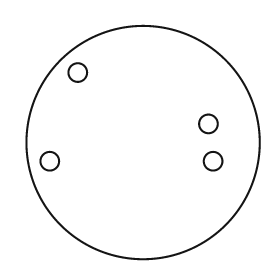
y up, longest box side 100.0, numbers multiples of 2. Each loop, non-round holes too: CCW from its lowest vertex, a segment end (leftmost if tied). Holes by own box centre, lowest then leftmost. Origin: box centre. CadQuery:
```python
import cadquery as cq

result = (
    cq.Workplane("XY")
    .moveTo(0.0, 0.0)
    .circle(50.0)
    .moveTo(-40.0, -8.0)
    .circle(4.0)
    .moveTo(30.0, -8.0)
    .circle(4.0)
    .moveTo(28.0, 8.0)
    .circle(4.0)
    .moveTo(-28.0, 30.0)
    .circle(4.0)
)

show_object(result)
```